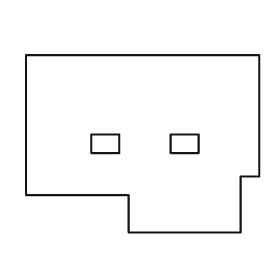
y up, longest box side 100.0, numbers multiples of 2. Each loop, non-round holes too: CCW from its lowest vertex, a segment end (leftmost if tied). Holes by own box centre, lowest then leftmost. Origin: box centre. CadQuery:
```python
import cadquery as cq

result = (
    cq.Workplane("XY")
    .moveTo(-6.0, -38.0)
    .lineTo(42.0, -38.0)
    .lineTo(42.0, -14.0)
    .lineTo(50.0, -14.0)
    .lineTo(50.0, 38.0)
    .lineTo(-50.0, 38.0)
    .lineTo(-50.0, -22.0)
    .lineTo(-6.0, -22.0)
    .close()
    .moveTo(-22.0, -4.0)
    .lineTo(-10.0, -4.0)
    .lineTo(-10.0, 4.0)
    .lineTo(-22.0, 4.0)
    .close()
    .moveTo(12.0, -4.0)
    .lineTo(24.0, -4.0)
    .lineTo(24.0, 4.0)
    .lineTo(12.0, 4.0)
    .close()
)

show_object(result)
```